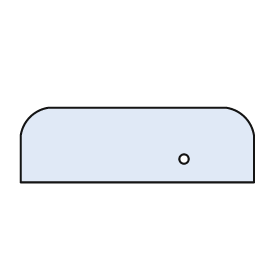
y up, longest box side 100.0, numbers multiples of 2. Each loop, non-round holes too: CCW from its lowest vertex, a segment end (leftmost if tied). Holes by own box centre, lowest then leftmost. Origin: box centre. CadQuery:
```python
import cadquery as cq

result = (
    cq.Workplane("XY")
    .moveTo(-50.0, -16.0)
    .lineTo(50.0, -16.0)
    .lineTo(50.0, 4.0)
    .threePointArc((46.0, 12.0), (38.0, 16.0))
    .lineTo(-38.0, 16.0)
    .threePointArc((-46.0, 12.0), (-50.0, 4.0))
    .close()
    .moveTo(20.0, -6.0)
    .circle(2.0)
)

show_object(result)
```